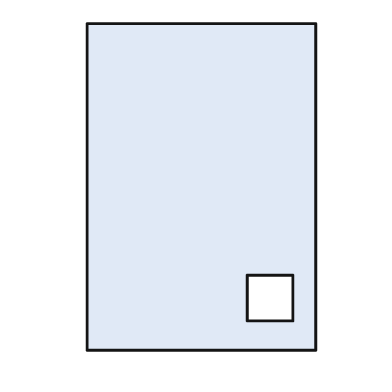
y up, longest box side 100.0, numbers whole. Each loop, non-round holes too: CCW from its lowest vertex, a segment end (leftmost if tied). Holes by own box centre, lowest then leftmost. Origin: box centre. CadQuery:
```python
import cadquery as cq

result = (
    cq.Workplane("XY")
    .moveTo(-35.0, -50.0)
    .lineTo(35.0, -50.0)
    .lineTo(35.0, 50.0)
    .lineTo(-35.0, 50.0)
    .close()
    .moveTo(14.0, -41.0)
    .lineTo(28.0, -41.0)
    .lineTo(28.0, -27.0)
    .lineTo(14.0, -27.0)
    .close()
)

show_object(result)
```